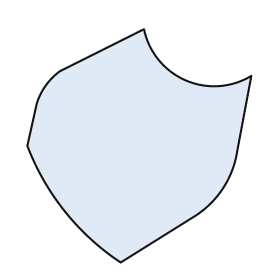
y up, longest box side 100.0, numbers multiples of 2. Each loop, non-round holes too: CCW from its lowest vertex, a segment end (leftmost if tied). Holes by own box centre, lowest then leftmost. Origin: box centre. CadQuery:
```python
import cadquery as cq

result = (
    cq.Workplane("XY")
    .moveTo(-8.0, -50.0)
    .lineTo(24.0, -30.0)
    .threePointArc((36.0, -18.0), (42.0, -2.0))
    .lineTo(48.0, 30.0)
    .threePointArc((20.0, 28.0), (2.0, 50.0))
    .lineTo(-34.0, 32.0)
    .threePointArc((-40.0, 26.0), (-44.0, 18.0))
    .lineTo(-48.0, 0.0)
    .threePointArc((-32.0, -28.0), (-8.0, -50.0))
    .close()
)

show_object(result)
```